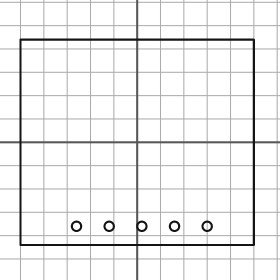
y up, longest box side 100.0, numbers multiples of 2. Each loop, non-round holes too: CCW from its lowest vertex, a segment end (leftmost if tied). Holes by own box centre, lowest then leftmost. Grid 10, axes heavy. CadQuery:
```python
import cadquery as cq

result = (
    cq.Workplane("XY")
    .moveTo(-50.0, -44.0)
    .lineTo(50.0, -44.0)
    .lineTo(50.0, 44.0)
    .lineTo(-50.0, 44.0)
    .close()
    .moveTo(-26.0, -36.0)
    .circle(2.0)
    .moveTo(-12.0, -36.0)
    .circle(2.0)
    .moveTo(2.0, -36.0)
    .circle(2.0)
    .moveTo(16.0, -36.0)
    .circle(2.0)
    .moveTo(30.0, -36.0)
    .circle(2.0)
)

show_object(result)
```